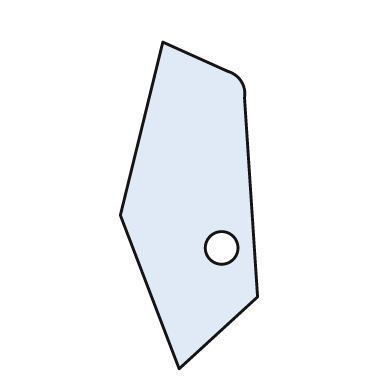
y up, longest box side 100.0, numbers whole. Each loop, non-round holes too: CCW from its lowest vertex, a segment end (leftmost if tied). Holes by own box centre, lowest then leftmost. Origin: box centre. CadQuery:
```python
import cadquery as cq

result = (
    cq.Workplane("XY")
    .moveTo(-3.0, -50.0)
    .lineTo(21.0, -28.0)
    .lineTo(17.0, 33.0)
    .threePointArc((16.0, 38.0), (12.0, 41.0))
    .lineTo(-8.0, 50.0)
    .lineTo(-21.0, -3.0)
    .close()
    .moveTo(10.0, -13.0)
    .circle(5.0)
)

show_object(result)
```